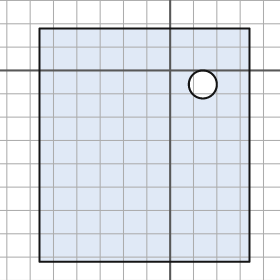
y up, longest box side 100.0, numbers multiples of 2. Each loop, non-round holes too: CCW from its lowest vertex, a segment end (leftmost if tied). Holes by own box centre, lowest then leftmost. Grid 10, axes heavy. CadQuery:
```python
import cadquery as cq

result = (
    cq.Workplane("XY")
    .moveTo(-56.0, -82.0)
    .lineTo(34.0, -82.0)
    .lineTo(34.0, 18.0)
    .lineTo(-56.0, 18.0)
    .close()
    .moveTo(14.0, -6.0)
    .circle(6.0)
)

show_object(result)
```